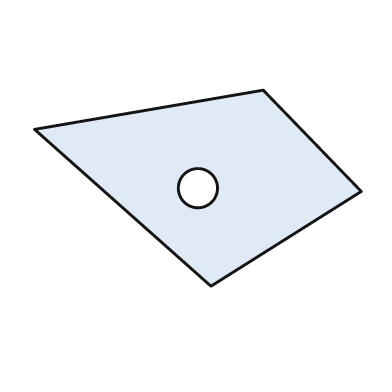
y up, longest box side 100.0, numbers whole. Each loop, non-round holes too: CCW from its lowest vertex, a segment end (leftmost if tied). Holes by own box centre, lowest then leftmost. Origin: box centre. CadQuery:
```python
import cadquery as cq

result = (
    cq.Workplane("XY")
    .moveTo(4.0, -30.0)
    .lineTo(50.0, -1.0)
    .lineTo(20.0, 30.0)
    .lineTo(-50.0, 18.0)
    .close()
    .moveTo(0.0, 0.0)
    .circle(6.0)
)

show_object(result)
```